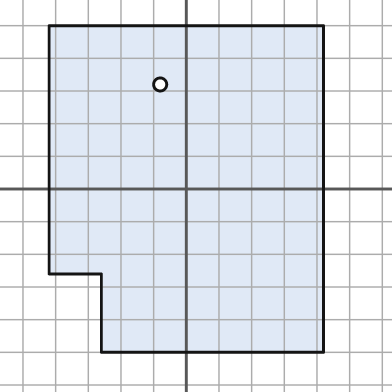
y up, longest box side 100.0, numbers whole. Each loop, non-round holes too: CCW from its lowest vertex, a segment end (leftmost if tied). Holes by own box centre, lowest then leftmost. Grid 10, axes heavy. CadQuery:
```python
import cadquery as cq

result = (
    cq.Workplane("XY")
    .moveTo(-26.0, -50.0)
    .lineTo(42.0, -50.0)
    .lineTo(42.0, 50.0)
    .lineTo(-42.0, 50.0)
    .lineTo(-42.0, -26.0)
    .lineTo(-26.0, -26.0)
    .close()
    .moveTo(-8.0, 32.0)
    .circle(2.0)
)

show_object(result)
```